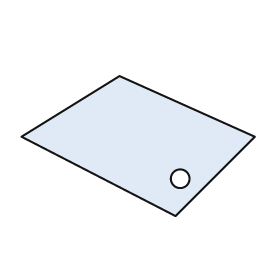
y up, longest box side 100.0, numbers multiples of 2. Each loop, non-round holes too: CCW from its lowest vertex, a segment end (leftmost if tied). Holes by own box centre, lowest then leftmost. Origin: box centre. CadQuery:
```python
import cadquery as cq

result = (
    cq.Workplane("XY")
    .moveTo(16.0, -30.0)
    .lineTo(50.0, 4.0)
    .lineTo(-8.0, 30.0)
    .lineTo(-50.0, 4.0)
    .close()
    .moveTo(18.0, -14.0)
    .circle(4.0)
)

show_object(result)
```